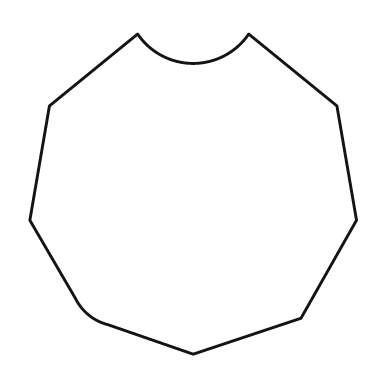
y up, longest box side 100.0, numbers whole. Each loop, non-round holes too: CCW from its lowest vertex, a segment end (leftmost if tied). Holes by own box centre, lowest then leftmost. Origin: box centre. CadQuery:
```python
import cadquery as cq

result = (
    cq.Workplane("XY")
    .moveTo(0.0, -49.0)
    .lineTo(33.0, -38.0)
    .lineTo(50.0, -8.0)
    .lineTo(44.0, 27.0)
    .lineTo(17.0, 49.0)
    .threePointArc((0.0, 40.0), (-17.0, 49.0))
    .lineTo(-44.0, 27.0)
    .lineTo(-50.0, -8.0)
    .lineTo(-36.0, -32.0)
    .threePointArc((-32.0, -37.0), (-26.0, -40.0))
    .close()
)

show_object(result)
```